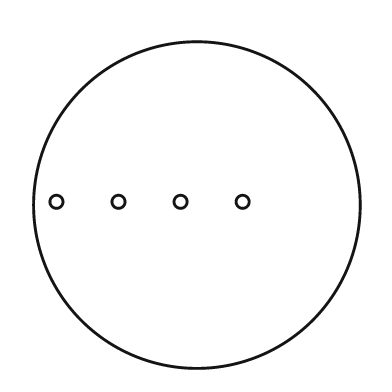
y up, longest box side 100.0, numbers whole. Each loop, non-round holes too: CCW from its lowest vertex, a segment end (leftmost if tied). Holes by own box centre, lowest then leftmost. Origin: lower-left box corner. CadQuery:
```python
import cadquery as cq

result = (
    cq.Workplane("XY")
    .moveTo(50.0, 50.0)
    .circle(50.0)
    .moveTo(7.0, 51.0)
    .circle(2.0)
    .moveTo(26.0, 51.0)
    .circle(2.0)
    .moveTo(45.0, 51.0)
    .circle(2.0)
    .moveTo(64.0, 51.0)
    .circle(2.0)
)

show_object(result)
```